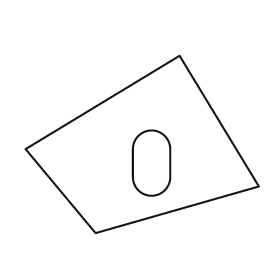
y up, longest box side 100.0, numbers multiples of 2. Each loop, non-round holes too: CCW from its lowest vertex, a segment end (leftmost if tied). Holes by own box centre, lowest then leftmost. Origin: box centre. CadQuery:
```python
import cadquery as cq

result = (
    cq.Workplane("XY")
    .moveTo(-20.0, -38.0)
    .lineTo(50.0, -18.0)
    .lineTo(16.0, 38.0)
    .lineTo(-50.0, -2.0)
    .close()
    .moveTo(-4.0, -14.0)
    .threePointArc((4.0, -22.0), (12.0, -14.0))
    .lineTo(12.0, -2.0)
    .threePointArc((4.0, 6.0), (-4.0, -2.0))
    .close()
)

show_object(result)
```